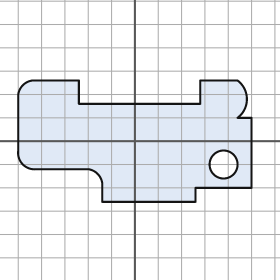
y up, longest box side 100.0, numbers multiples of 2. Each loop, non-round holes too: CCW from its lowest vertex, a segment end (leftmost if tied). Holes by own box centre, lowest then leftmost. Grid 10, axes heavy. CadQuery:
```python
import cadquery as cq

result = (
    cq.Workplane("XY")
    .moveTo(-14.0, -26.0)
    .lineTo(26.0, -26.0)
    .lineTo(26.0, -20.0)
    .lineTo(50.0, -20.0)
    .lineTo(50.0, 10.0)
    .lineTo(44.0, 10.0)
    .threePointArc((48.0, 18.0), (44.0, 26.0))
    .lineTo(28.0, 26.0)
    .lineTo(28.0, 16.0)
    .lineTo(-24.0, 16.0)
    .lineTo(-24.0, 26.0)
    .lineTo(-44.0, 26.0)
    .threePointArc((-48.0, 24.0), (-50.0, 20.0))
    .lineTo(-50.0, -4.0)
    .threePointArc((-48.0, -10.0), (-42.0, -12.0))
    .lineTo(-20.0, -12.0)
    .threePointArc((-16.0, -14.0), (-14.0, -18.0))
    .close()
    .moveTo(38.0, -10.0)
    .circle(6.0)
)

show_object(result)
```